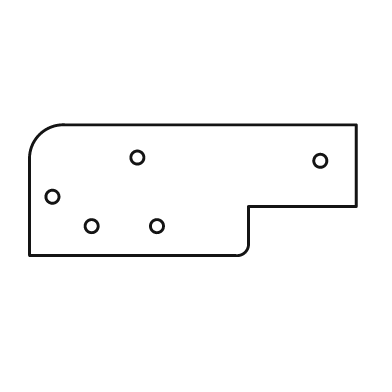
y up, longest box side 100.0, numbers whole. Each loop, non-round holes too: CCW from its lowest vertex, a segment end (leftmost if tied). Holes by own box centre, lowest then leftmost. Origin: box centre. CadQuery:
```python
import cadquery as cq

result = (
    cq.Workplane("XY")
    .moveTo(-50.0, -20.0)
    .lineTo(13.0, -20.0)
    .threePointArc((16.0, -19.0), (17.0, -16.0))
    .lineTo(17.0, -5.0)
    .lineTo(50.0, -5.0)
    .lineTo(50.0, 20.0)
    .lineTo(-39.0, 20.0)
    .threePointArc((-47.0, 17.0), (-50.0, 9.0))
    .close()
    .moveTo(-31.0, -11.0)
    .circle(2.0)
    .moveTo(-11.0, -11.0)
    .circle(2.0)
    .moveTo(-43.0, -2.0)
    .circle(2.0)
    .moveTo(39.0, 9.0)
    .circle(2.0)
    .moveTo(-17.0, 10.0)
    .circle(2.0)
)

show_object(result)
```